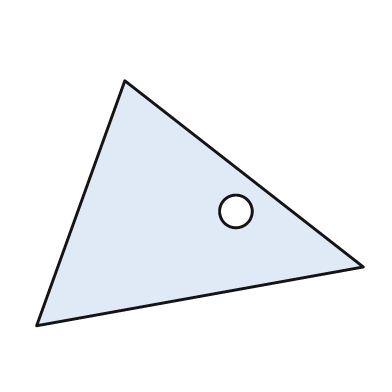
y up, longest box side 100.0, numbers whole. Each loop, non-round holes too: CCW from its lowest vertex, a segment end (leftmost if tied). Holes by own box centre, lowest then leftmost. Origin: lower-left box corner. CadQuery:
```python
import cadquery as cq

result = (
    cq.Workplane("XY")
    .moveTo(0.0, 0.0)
    .lineTo(100.0, 18.0)
    .lineTo(27.0, 75.0)
    .close()
    .moveTo(61.0, 35.0)
    .circle(5.0)
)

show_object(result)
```